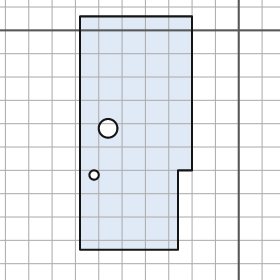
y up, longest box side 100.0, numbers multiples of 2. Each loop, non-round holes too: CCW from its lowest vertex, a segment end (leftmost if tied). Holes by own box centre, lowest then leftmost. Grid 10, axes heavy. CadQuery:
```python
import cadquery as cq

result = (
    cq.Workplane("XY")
    .moveTo(-68.0, -94.0)
    .lineTo(-26.0, -94.0)
    .lineTo(-26.0, -60.0)
    .lineTo(-20.0, -60.0)
    .lineTo(-20.0, 6.0)
    .lineTo(-68.0, 6.0)
    .close()
    .moveTo(-62.0, -62.0)
    .circle(2.0)
    .moveTo(-56.0, -42.0)
    .circle(4.0)
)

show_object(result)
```